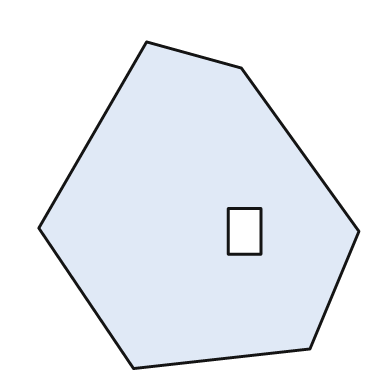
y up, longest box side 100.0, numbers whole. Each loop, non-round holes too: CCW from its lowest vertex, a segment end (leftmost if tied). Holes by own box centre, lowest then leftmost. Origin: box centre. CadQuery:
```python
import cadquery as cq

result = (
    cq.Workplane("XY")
    .moveTo(-20.0, -50.0)
    .lineTo(34.0, -44.0)
    .lineTo(49.0, -8.0)
    .lineTo(13.0, 42.0)
    .lineTo(-16.0, 50.0)
    .lineTo(-49.0, -7.0)
    .close()
    .moveTo(9.0, -15.0)
    .lineTo(19.0, -15.0)
    .lineTo(19.0, -1.0)
    .lineTo(9.0, -1.0)
    .close()
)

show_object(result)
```